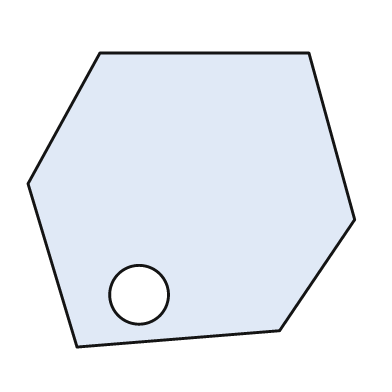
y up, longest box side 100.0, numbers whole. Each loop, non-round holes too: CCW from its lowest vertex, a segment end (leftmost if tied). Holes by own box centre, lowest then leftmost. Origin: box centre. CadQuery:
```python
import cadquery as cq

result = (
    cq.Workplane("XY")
    .moveTo(-35.0, -45.0)
    .lineTo(27.0, -40.0)
    .lineTo(50.0, -6.0)
    .lineTo(36.0, 45.0)
    .lineTo(-28.0, 45.0)
    .lineTo(-50.0, 5.0)
    .close()
    .moveTo(-16.0, -29.0)
    .circle(9.0)
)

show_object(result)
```